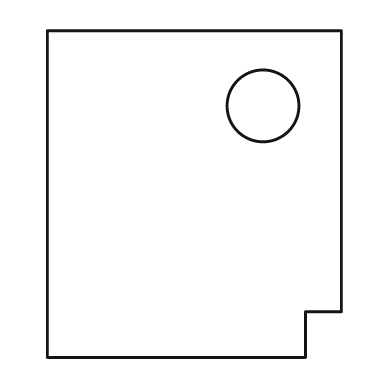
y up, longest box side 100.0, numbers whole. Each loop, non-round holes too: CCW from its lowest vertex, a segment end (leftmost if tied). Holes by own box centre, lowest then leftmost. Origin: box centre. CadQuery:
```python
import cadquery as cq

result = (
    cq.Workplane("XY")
    .moveTo(-45.0, -50.0)
    .lineTo(34.0, -50.0)
    .lineTo(34.0, -36.0)
    .lineTo(45.0, -36.0)
    .lineTo(45.0, 50.0)
    .lineTo(-45.0, 50.0)
    .close()
    .moveTo(21.0, 27.0)
    .circle(11.0)
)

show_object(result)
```